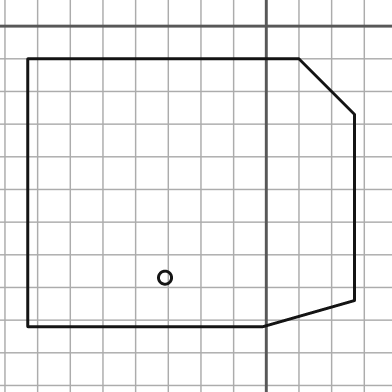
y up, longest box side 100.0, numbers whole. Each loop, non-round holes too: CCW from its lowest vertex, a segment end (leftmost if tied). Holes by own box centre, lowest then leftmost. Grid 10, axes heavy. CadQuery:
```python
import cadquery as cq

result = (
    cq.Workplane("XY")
    .moveTo(-73.0, -92.0)
    .lineTo(-1.0, -92.0)
    .lineTo(27.0, -84.0)
    .lineTo(27.0, -27.0)
    .lineTo(10.0, -10.0)
    .lineTo(-73.0, -10.0)
    .close()
    .moveTo(-31.0, -77.0)
    .circle(2.0)
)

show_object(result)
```